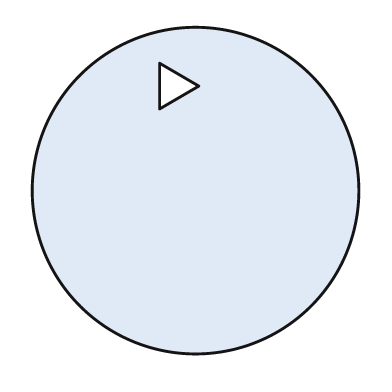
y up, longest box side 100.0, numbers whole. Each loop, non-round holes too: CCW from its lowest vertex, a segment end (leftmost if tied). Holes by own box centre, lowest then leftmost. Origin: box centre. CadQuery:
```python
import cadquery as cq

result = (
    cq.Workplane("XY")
    .moveTo(0.0, 0.0)
    .circle(50.0)
    .moveTo(-11.0, 25.0)
    .lineTo(1.0, 32.0)
    .lineTo(-11.0, 39.0)
    .close()
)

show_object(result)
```